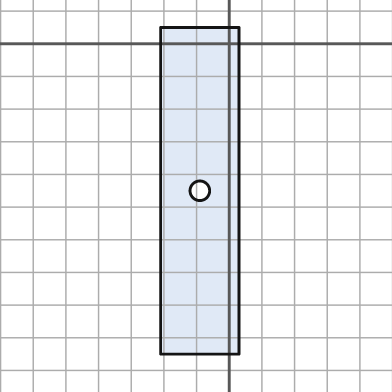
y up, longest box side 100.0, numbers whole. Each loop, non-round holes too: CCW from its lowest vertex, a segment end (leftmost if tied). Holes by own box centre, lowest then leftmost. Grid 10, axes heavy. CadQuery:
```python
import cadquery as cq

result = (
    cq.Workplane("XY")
    .moveTo(-21.0, -95.0)
    .lineTo(3.0, -95.0)
    .lineTo(3.0, 5.0)
    .lineTo(-21.0, 5.0)
    .close()
    .moveTo(-9.0, -45.0)
    .circle(3.0)
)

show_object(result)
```